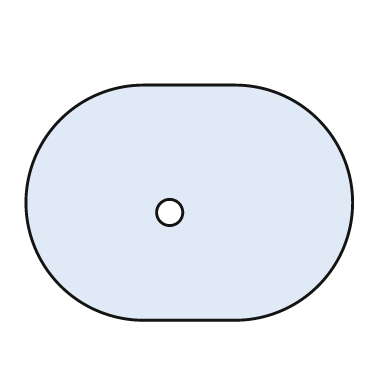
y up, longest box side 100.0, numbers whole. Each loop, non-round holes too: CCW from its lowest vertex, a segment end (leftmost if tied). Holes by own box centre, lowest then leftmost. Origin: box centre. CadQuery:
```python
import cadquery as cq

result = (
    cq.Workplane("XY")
    .moveTo(-14.0, -36.0)
    .lineTo(14.0, -36.0)
    .threePointArc((50.0, 0.0), (14.0, 36.0))
    .lineTo(-14.0, 36.0)
    .threePointArc((-50.0, 0.0), (-14.0, -36.0))
    .close()
    .moveTo(-6.0, -3.0)
    .circle(4.0)
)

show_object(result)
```